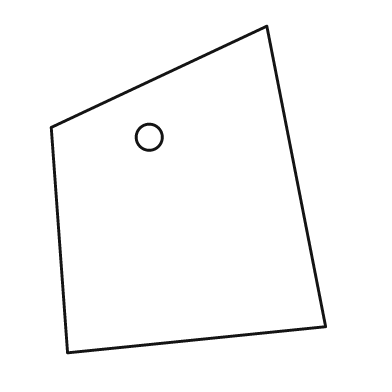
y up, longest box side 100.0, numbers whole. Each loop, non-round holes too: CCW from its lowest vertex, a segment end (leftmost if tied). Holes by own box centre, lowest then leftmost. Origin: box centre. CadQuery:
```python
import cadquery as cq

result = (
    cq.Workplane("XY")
    .moveTo(-37.0, -50.0)
    .lineTo(42.0, -42.0)
    .lineTo(24.0, 50.0)
    .lineTo(-42.0, 19.0)
    .close()
    .moveTo(-12.0, 16.0)
    .circle(4.0)
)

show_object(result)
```